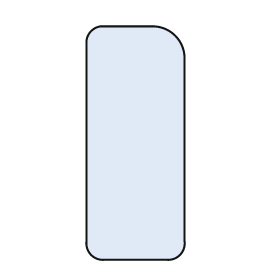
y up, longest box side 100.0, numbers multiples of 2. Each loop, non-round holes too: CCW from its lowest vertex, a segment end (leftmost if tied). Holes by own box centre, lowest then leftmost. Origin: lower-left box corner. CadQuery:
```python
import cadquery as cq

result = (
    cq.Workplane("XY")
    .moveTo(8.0, 0.0)
    .lineTo(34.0, 0.0)
    .threePointArc((40.0, 2.0), (42.0, 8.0))
    .lineTo(42.0, 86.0)
    .threePointArc((38.0, 96.0), (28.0, 100.0))
    .lineTo(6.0, 100.0)
    .threePointArc((2.0, 98.0), (0.0, 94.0))
    .lineTo(0.0, 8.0)
    .threePointArc((2.0, 2.0), (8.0, 0.0))
    .close()
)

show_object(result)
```